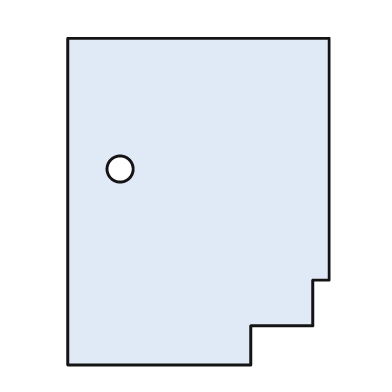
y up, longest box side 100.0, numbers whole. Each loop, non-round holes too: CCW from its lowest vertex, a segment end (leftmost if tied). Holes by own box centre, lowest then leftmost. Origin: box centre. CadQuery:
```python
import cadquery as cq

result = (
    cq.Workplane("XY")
    .moveTo(-40.0, -50.0)
    .lineTo(16.0, -50.0)
    .lineTo(16.0, -38.0)
    .lineTo(35.0, -38.0)
    .lineTo(35.0, -24.0)
    .lineTo(40.0, -24.0)
    .lineTo(40.0, 50.0)
    .lineTo(-40.0, 50.0)
    .close()
    .moveTo(-24.0, 10.0)
    .circle(4.0)
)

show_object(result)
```